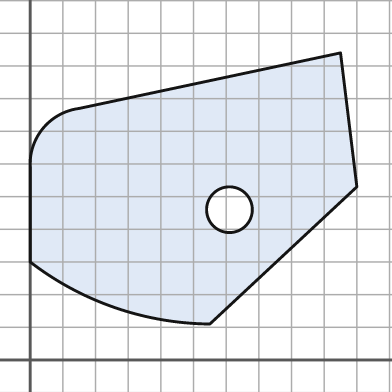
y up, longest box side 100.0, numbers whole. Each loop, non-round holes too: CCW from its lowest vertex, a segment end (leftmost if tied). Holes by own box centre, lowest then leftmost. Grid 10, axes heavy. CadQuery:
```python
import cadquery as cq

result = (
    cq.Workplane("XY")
    .moveTo(55.0, 11.0)
    .lineTo(100.0, 53.0)
    .lineTo(95.0, 94.0)
    .lineTo(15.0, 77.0)
    .threePointArc((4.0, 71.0), (0.0, 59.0))
    .lineTo(0.0, 30.0)
    .threePointArc((26.0, 16.0), (55.0, 11.0))
    .close()
    .moveTo(61.0, 46.0)
    .circle(7.0)
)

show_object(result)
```